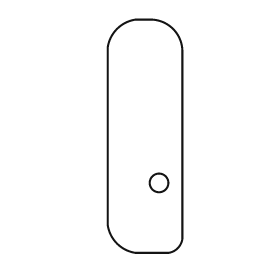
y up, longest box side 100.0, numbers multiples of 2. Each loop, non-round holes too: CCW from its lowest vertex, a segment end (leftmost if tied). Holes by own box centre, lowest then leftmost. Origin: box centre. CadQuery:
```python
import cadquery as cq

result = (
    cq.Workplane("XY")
    .moveTo(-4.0, -50.0)
    .lineTo(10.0, -50.0)
    .threePointArc((14.0, -48.0), (16.0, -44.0))
    .lineTo(16.0, 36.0)
    .threePointArc((12.0, 46.0), (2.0, 50.0))
    .lineTo(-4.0, 50.0)
    .threePointArc((-12.0, 46.0), (-16.0, 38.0))
    .lineTo(-16.0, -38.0)
    .threePointArc((-12.0, -46.0), (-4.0, -50.0))
    .close()
    .moveTo(6.0, -20.0)
    .circle(4.0)
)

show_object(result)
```